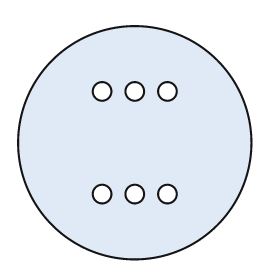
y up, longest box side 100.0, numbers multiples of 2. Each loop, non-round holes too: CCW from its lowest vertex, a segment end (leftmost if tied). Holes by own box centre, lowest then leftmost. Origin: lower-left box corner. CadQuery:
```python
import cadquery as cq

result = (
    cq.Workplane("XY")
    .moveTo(50.0, 50.0)
    .circle(50.0)
    .moveTo(36.0, 28.0)
    .circle(4.0)
    .moveTo(50.0, 28.0)
    .circle(4.0)
    .moveTo(64.0, 28.0)
    .circle(4.0)
    .moveTo(36.0, 72.0)
    .circle(4.0)
    .moveTo(50.0, 72.0)
    .circle(4.0)
    .moveTo(64.0, 72.0)
    .circle(4.0)
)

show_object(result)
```